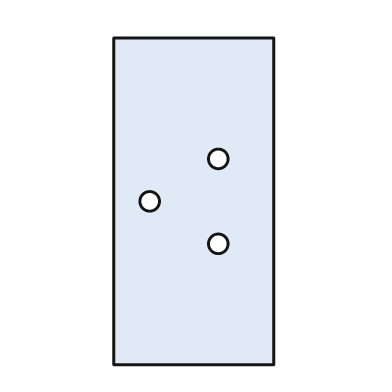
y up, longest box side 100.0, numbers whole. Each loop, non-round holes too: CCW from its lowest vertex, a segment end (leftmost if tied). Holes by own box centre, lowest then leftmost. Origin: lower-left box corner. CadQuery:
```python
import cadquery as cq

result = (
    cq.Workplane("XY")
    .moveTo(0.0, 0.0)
    .lineTo(49.0, 0.0)
    .lineTo(49.0, 100.0)
    .lineTo(0.0, 100.0)
    .close()
    .moveTo(32.0, 37.0)
    .circle(3.0)
    .moveTo(11.0, 50.0)
    .circle(3.0)
    .moveTo(32.0, 63.0)
    .circle(3.0)
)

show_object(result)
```